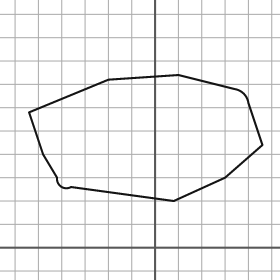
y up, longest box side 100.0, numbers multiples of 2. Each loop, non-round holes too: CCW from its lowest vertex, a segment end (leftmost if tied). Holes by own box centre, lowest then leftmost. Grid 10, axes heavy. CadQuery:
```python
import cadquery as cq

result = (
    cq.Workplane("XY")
    .moveTo(8.0, 20.0)
    .lineTo(30.0, 30.0)
    .lineTo(46.0, 44.0)
    .lineTo(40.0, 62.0)
    .threePointArc((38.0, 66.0), (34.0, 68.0))
    .lineTo(10.0, 74.0)
    .lineTo(-20.0, 72.0)
    .lineTo(-54.0, 58.0)
    .lineTo(-48.0, 40.0)
    .lineTo(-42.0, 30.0)
    .threePointArc((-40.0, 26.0), (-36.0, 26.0))
    .close()
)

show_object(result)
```